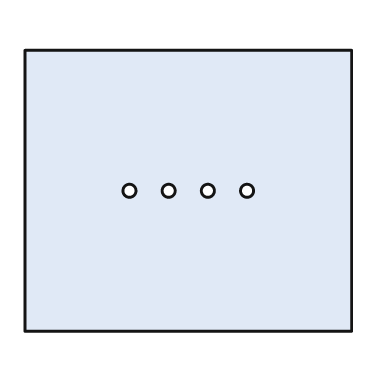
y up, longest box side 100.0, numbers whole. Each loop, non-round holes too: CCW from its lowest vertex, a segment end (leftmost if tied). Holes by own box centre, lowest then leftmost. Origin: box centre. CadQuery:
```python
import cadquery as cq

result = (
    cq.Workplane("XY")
    .moveTo(-50.0, -43.0)
    .lineTo(50.0, -43.0)
    .lineTo(50.0, 43.0)
    .lineTo(-50.0, 43.0)
    .close()
    .moveTo(-18.0, 0.0)
    .circle(2.0)
    .moveTo(-6.0, 0.0)
    .circle(2.0)
    .moveTo(6.0, 0.0)
    .circle(2.0)
    .moveTo(18.0, 0.0)
    .circle(2.0)
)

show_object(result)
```